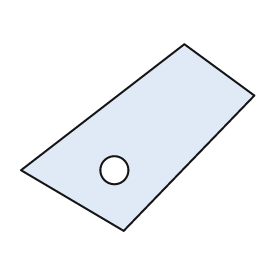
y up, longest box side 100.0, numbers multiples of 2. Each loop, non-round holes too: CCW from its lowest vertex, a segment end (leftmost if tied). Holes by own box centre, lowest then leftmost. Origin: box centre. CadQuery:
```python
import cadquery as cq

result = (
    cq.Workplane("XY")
    .moveTo(-6.0, -40.0)
    .lineTo(50.0, 18.0)
    .lineTo(20.0, 40.0)
    .lineTo(-50.0, -14.0)
    .close()
    .moveTo(-10.0, -14.0)
    .circle(6.0)
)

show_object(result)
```